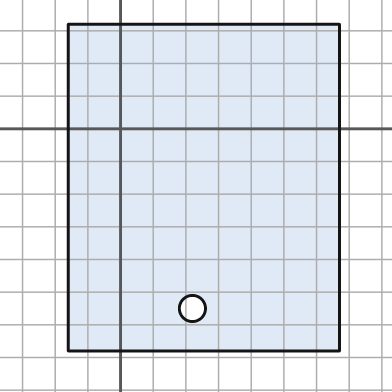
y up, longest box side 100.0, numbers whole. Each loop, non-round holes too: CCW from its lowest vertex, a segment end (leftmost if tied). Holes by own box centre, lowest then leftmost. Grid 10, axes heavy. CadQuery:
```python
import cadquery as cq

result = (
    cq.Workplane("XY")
    .moveTo(-16.0, -68.0)
    .lineTo(67.0, -68.0)
    .lineTo(67.0, 32.0)
    .lineTo(-16.0, 32.0)
    .close()
    .moveTo(22.0, -55.0)
    .circle(4.0)
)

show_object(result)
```